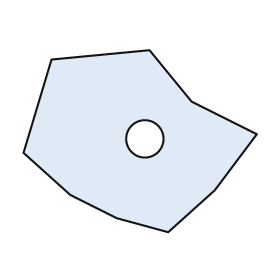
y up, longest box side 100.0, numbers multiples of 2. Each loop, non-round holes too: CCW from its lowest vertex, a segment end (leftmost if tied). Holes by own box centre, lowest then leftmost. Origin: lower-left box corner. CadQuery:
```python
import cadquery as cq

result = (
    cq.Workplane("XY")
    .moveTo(62.0, 0.0)
    .lineTo(82.0, 18.0)
    .lineTo(100.0, 42.0)
    .lineTo(72.0, 56.0)
    .lineTo(54.0, 78.0)
    .lineTo(12.0, 74.0)
    .lineTo(0.0, 34.0)
    .lineTo(20.0, 16.0)
    .lineTo(40.0, 6.0)
    .close()
    .moveTo(52.0, 40.0)
    .circle(8.0)
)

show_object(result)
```